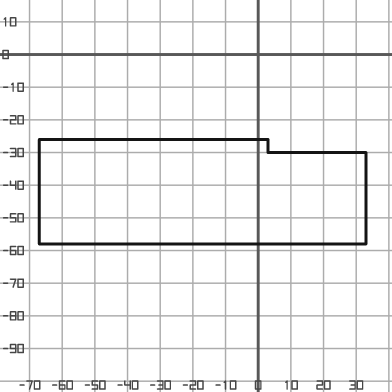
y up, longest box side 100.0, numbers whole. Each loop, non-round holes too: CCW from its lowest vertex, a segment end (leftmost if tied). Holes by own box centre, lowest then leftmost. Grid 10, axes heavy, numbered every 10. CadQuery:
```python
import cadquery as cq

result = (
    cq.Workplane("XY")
    .moveTo(-67.0, -58.0)
    .lineTo(33.0, -58.0)
    .lineTo(33.0, -30.0)
    .lineTo(3.0, -30.0)
    .lineTo(3.0, -26.0)
    .lineTo(-67.0, -26.0)
    .close()
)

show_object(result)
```